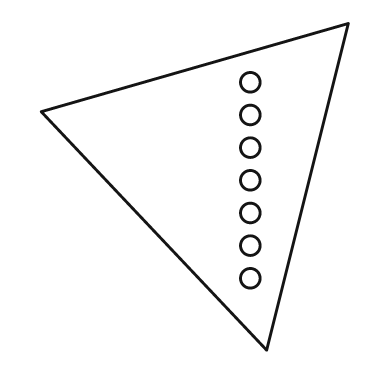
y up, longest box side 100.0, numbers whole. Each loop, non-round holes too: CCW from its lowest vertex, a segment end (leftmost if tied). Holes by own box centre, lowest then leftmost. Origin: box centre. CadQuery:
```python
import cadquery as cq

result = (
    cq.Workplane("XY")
    .moveTo(22.0, -50.0)
    .lineTo(47.0, 50.0)
    .lineTo(-47.0, 23.0)
    .close()
    .moveTo(17.0, -28.0)
    .circle(3.0)
    .moveTo(17.0, -18.0)
    .circle(3.0)
    .moveTo(17.0, -8.0)
    .circle(3.0)
    .moveTo(17.0, 2.0)
    .circle(3.0)
    .moveTo(17.0, 12.0)
    .circle(3.0)
    .moveTo(17.0, 22.0)
    .circle(3.0)
    .moveTo(17.0, 32.0)
    .circle(3.0)
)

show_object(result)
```